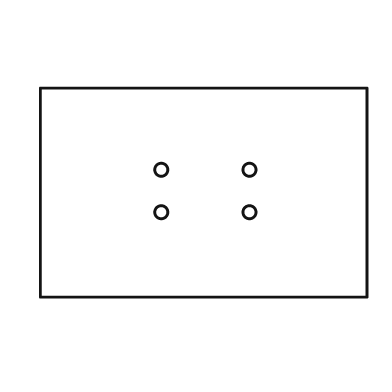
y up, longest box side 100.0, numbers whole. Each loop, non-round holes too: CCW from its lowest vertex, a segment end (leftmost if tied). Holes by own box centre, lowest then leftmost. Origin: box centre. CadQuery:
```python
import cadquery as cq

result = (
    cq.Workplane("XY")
    .moveTo(-50.0, -32.0)
    .lineTo(50.0, -32.0)
    .lineTo(50.0, 32.0)
    .lineTo(-50.0, 32.0)
    .close()
    .moveTo(-13.0, -6.0)
    .circle(2.0)
    .moveTo(14.0, -6.0)
    .circle(2.0)
    .moveTo(-13.0, 7.0)
    .circle(2.0)
    .moveTo(14.0, 7.0)
    .circle(2.0)
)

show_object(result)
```